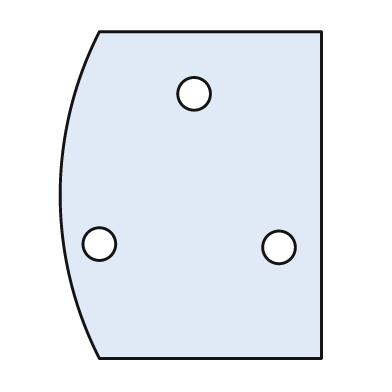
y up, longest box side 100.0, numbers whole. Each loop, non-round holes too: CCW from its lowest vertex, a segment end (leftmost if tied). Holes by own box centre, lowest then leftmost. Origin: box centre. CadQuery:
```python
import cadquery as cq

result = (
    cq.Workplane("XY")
    .moveTo(-28.0, -50.0)
    .lineTo(40.0, -50.0)
    .lineTo(40.0, 50.0)
    .lineTo(-28.0, 50.0)
    .threePointArc((-40.0, 0.0), (-28.0, -50.0))
    .close()
    .moveTo(27.0, -16.0)
    .circle(5.0)
    .moveTo(-28.0, -15.0)
    .circle(5.0)
    .moveTo(1.0, 31.0)
    .circle(5.0)
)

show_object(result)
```